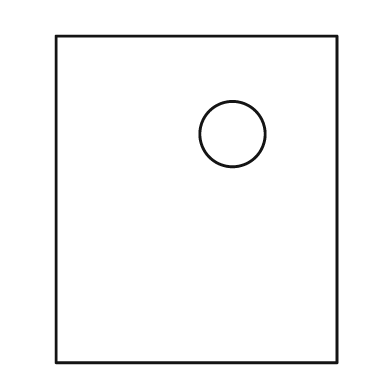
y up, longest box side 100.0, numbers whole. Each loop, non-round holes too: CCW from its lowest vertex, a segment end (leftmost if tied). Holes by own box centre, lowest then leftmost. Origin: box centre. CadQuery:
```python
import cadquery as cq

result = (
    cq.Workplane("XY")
    .moveTo(-43.0, -50.0)
    .lineTo(43.0, -50.0)
    .lineTo(43.0, 50.0)
    .lineTo(-43.0, 50.0)
    .close()
    .moveTo(11.0, 20.0)
    .circle(10.0)
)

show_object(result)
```